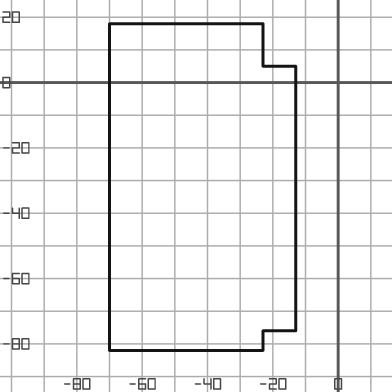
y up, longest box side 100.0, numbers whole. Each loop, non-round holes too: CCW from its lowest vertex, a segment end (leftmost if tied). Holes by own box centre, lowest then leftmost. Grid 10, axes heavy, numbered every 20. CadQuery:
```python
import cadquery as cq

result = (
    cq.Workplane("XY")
    .moveTo(-70.0, -82.0)
    .lineTo(-23.0, -82.0)
    .lineTo(-23.0, -76.0)
    .lineTo(-13.0, -76.0)
    .lineTo(-13.0, 5.0)
    .lineTo(-23.0, 5.0)
    .lineTo(-23.0, 18.0)
    .lineTo(-70.0, 18.0)
    .close()
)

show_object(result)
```